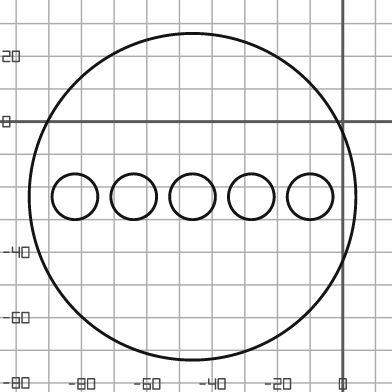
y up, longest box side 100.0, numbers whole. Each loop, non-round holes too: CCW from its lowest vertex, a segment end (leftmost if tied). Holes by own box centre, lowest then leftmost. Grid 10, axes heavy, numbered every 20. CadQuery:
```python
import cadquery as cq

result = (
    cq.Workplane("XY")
    .moveTo(-46.0, -23.0)
    .circle(50.0)
    .moveTo(-82.0, -23.0)
    .circle(7.0)
    .moveTo(-64.0, -23.0)
    .circle(7.0)
    .moveTo(-46.0, -23.0)
    .circle(7.0)
    .moveTo(-28.0, -23.0)
    .circle(7.0)
    .moveTo(-10.0, -23.0)
    .circle(7.0)
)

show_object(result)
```